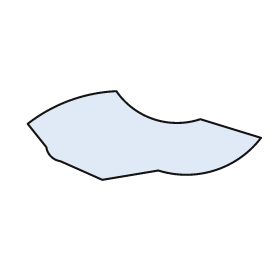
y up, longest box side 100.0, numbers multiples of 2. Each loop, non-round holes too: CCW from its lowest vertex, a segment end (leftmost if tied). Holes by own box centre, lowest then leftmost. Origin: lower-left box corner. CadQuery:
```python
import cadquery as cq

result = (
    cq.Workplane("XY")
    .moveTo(32.0, 0.0)
    .lineTo(56.0, 4.0)
    .threePointArc((80.0, 4.0), (100.0, 18.0))
    .lineTo(74.0, 26.0)
    .threePointArc((54.0, 26.0), (38.0, 38.0))
    .threePointArc((18.0, 34.0), (0.0, 24.0))
    .lineTo(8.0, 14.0)
    .threePointArc((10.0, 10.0), (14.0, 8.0))
    .close()
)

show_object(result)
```